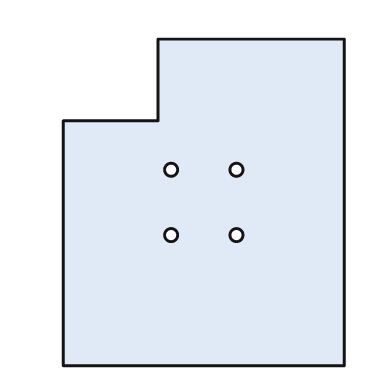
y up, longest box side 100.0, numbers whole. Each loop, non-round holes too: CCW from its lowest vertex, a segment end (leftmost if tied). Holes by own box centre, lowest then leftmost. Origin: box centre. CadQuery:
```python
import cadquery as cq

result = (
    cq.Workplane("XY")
    .moveTo(-43.0, -50.0)
    .lineTo(43.0, -50.0)
    .lineTo(43.0, 50.0)
    .lineTo(-14.0, 50.0)
    .lineTo(-14.0, 25.0)
    .lineTo(-43.0, 25.0)
    .close()
    .moveTo(-10.0, -10.0)
    .circle(2.0)
    .moveTo(10.0, -10.0)
    .circle(2.0)
    .moveTo(-10.0, 10.0)
    .circle(2.0)
    .moveTo(10.0, 10.0)
    .circle(2.0)
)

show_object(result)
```